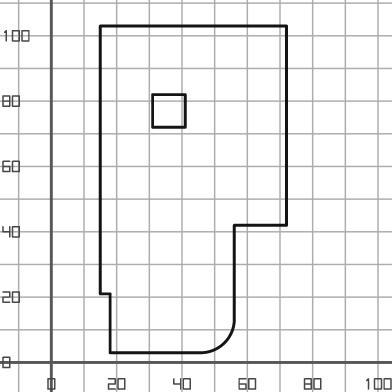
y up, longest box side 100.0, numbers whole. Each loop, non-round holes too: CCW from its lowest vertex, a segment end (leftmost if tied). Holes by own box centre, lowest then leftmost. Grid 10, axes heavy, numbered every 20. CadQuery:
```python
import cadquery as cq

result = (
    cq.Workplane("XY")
    .moveTo(18.0, 3.0)
    .lineTo(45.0, 3.0)
    .threePointArc((53.0, 6.0), (56.0, 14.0))
    .lineTo(56.0, 42.0)
    .lineTo(72.0, 42.0)
    .lineTo(72.0, 103.0)
    .lineTo(15.0, 103.0)
    .lineTo(15.0, 21.0)
    .lineTo(18.0, 21.0)
    .close()
    .moveTo(31.0, 72.0)
    .lineTo(41.0, 72.0)
    .lineTo(41.0, 82.0)
    .lineTo(31.0, 82.0)
    .close()
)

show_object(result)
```